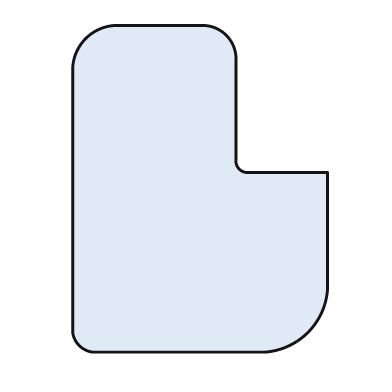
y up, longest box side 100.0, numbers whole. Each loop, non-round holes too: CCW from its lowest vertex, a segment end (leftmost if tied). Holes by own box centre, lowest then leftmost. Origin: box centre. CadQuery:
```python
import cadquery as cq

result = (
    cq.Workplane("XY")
    .moveTo(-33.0, -50.0)
    .lineTo(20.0, -50.0)
    .threePointArc((33.0, -44.0), (39.0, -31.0))
    .lineTo(39.0, 5.0)
    .lineTo(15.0, 5.0)
    .threePointArc((12.0, 6.0), (11.0, 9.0))
    .lineTo(11.0, 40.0)
    .threePointArc((8.0, 47.0), (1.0, 50.0))
    .lineTo(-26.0, 50.0)
    .threePointArc((-35.0, 46.0), (-39.0, 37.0))
    .lineTo(-39.0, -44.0)
    .threePointArc((-37.0, -48.0), (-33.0, -50.0))
    .close()
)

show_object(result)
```